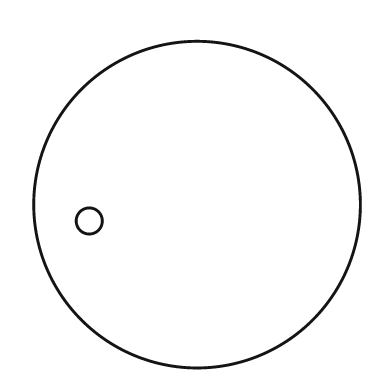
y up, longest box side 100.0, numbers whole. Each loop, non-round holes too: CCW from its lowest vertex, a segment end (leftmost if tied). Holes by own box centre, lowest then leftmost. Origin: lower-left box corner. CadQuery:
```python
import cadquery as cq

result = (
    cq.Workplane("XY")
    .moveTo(50.0, 50.0)
    .circle(50.0)
    .moveTo(17.0, 45.0)
    .circle(4.0)
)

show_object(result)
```